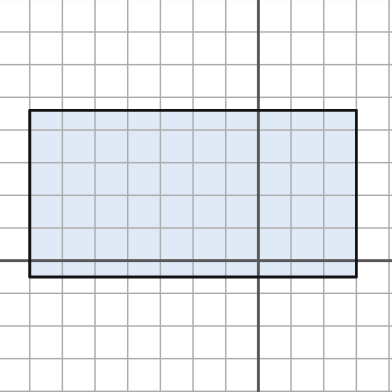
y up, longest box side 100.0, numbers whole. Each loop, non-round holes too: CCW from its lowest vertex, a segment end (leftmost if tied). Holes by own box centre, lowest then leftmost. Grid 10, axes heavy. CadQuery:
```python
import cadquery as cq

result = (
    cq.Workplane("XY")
    .moveTo(-70.0, -5.0)
    .lineTo(30.0, -5.0)
    .lineTo(30.0, 46.0)
    .lineTo(-70.0, 46.0)
    .close()
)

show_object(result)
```